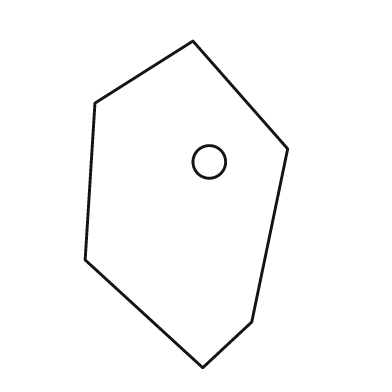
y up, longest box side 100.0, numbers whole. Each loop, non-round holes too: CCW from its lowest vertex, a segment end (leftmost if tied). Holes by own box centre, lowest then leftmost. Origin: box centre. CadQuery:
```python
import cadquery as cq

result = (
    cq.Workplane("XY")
    .moveTo(5.0, -50.0)
    .lineTo(20.0, -36.0)
    .lineTo(31.0, 17.0)
    .lineTo(2.0, 50.0)
    .lineTo(-28.0, 31.0)
    .lineTo(-31.0, -17.0)
    .close()
    .moveTo(7.0, 13.0)
    .circle(5.0)
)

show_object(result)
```